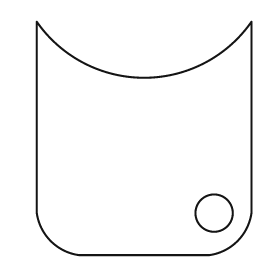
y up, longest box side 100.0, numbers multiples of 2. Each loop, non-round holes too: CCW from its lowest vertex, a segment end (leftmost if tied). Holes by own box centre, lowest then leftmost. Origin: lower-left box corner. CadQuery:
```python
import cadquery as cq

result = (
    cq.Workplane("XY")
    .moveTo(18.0, 0.0)
    .lineTo(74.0, 0.0)
    .threePointArc((86.0, 6.0), (92.0, 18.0))
    .lineTo(92.0, 100.0)
    .threePointArc((46.0, 76.0), (0.0, 100.0))
    .lineTo(0.0, 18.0)
    .threePointArc((6.0, 6.0), (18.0, 0.0))
    .close()
    .moveTo(76.0, 18.0)
    .circle(8.0)
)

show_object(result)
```